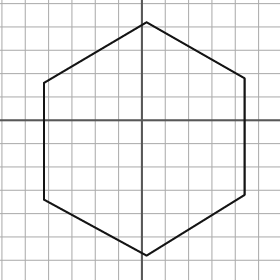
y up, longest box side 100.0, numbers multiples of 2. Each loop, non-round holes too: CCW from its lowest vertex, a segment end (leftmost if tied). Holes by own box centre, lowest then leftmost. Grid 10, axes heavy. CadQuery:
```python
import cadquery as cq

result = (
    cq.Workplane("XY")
    .moveTo(2.0, -58.0)
    .lineTo(44.0, -32.0)
    .lineTo(44.0, 18.0)
    .lineTo(2.0, 42.0)
    .lineTo(-42.0, 16.0)
    .lineTo(-42.0, -34.0)
    .close()
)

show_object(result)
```